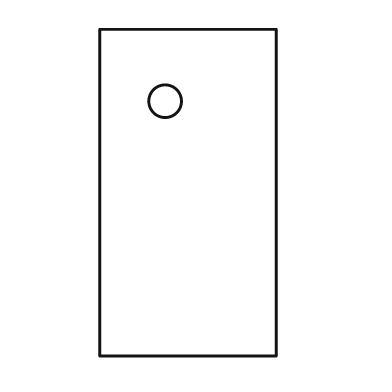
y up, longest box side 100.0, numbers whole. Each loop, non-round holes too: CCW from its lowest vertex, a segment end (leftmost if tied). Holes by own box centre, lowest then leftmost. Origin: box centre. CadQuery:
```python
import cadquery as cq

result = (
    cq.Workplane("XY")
    .moveTo(-27.0, -50.0)
    .lineTo(27.0, -50.0)
    .lineTo(27.0, 50.0)
    .lineTo(-27.0, 50.0)
    .close()
    .moveTo(-7.0, 28.0)
    .circle(5.0)
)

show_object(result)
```